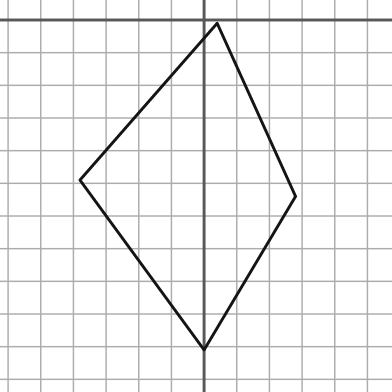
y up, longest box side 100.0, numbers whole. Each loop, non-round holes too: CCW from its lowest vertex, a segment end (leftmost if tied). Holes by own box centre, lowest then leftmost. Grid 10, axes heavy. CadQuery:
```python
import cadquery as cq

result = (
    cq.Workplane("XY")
    .moveTo(0.0, -101.0)
    .lineTo(28.0, -54.0)
    .lineTo(4.0, -1.0)
    .lineTo(-38.0, -49.0)
    .close()
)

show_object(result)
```